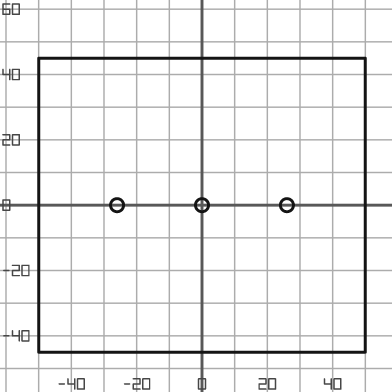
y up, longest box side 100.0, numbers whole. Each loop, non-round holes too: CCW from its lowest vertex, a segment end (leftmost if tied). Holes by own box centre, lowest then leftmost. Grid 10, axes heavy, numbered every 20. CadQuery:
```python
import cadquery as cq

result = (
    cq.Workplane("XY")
    .moveTo(-50.0, -45.0)
    .lineTo(50.0, -45.0)
    .lineTo(50.0, 45.0)
    .lineTo(-50.0, 45.0)
    .close()
    .moveTo(-26.0, 0.0)
    .circle(2.0)
    .moveTo(0.0, 0.0)
    .circle(2.0)
    .moveTo(26.0, 0.0)
    .circle(2.0)
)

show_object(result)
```